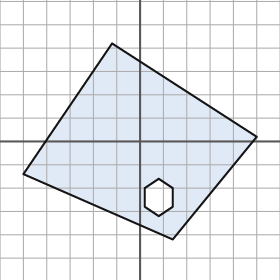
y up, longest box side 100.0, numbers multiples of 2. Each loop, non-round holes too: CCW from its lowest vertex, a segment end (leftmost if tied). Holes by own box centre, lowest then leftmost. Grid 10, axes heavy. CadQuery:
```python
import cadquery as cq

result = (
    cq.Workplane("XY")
    .moveTo(14.0, -42.0)
    .lineTo(50.0, 2.0)
    .lineTo(-12.0, 42.0)
    .lineTo(-50.0, -14.0)
    .close()
    .moveTo(8.0, -32.0)
    .lineTo(14.0, -28.0)
    .lineTo(14.0, -20.0)
    .lineTo(8.0, -16.0)
    .lineTo(2.0, -20.0)
    .lineTo(2.0, -28.0)
    .close()
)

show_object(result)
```